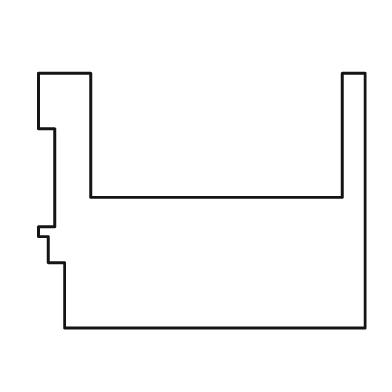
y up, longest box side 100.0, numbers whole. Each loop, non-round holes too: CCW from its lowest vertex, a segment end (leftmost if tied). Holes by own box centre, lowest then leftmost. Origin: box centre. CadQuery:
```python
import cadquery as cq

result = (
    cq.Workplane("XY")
    .moveTo(-42.0, -39.0)
    .lineTo(50.0, -39.0)
    .lineTo(50.0, 39.0)
    .lineTo(43.0, 39.0)
    .lineTo(43.0, 1.0)
    .lineTo(-34.0, 1.0)
    .lineTo(-34.0, 39.0)
    .lineTo(-50.0, 39.0)
    .lineTo(-50.0, 22.0)
    .lineTo(-45.0, 22.0)
    .lineTo(-45.0, -8.0)
    .lineTo(-50.0, -8.0)
    .lineTo(-50.0, -11.0)
    .lineTo(-47.0, -11.0)
    .lineTo(-47.0, -19.0)
    .lineTo(-42.0, -19.0)
    .close()
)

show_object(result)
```